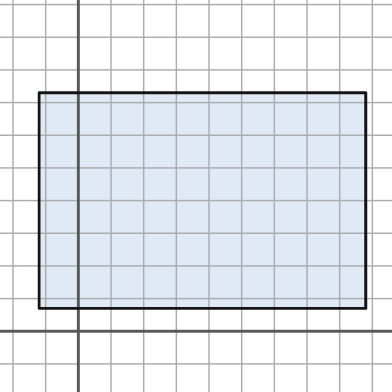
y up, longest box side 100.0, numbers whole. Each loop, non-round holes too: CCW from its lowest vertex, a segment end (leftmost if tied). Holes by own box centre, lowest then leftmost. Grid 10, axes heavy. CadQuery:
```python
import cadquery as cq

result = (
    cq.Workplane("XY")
    .moveTo(-12.0, 7.0)
    .lineTo(88.0, 7.0)
    .lineTo(88.0, 73.0)
    .lineTo(-12.0, 73.0)
    .close()
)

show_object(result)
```